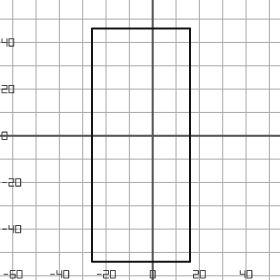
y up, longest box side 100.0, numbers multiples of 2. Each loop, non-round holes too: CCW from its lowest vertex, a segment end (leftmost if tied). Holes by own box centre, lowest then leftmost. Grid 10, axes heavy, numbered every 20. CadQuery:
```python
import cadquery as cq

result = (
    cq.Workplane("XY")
    .moveTo(-26.0, -54.0)
    .lineTo(16.0, -54.0)
    .lineTo(16.0, 46.0)
    .lineTo(-26.0, 46.0)
    .close()
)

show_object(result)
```